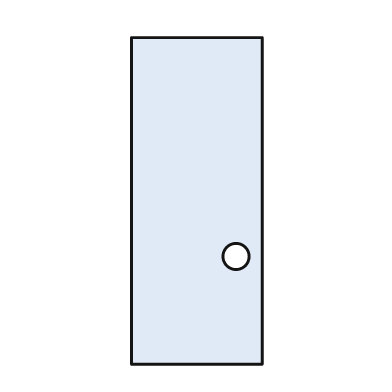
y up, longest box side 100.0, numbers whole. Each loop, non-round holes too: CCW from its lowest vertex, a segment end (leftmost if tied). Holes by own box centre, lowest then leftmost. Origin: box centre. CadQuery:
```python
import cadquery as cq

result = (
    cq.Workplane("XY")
    .moveTo(-20.0, -50.0)
    .lineTo(20.0, -50.0)
    .lineTo(20.0, 50.0)
    .lineTo(-20.0, 50.0)
    .close()
    .moveTo(12.0, -17.0)
    .circle(4.0)
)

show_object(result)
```